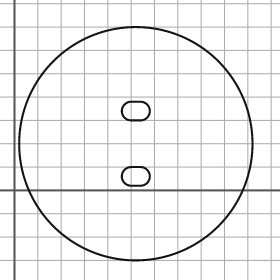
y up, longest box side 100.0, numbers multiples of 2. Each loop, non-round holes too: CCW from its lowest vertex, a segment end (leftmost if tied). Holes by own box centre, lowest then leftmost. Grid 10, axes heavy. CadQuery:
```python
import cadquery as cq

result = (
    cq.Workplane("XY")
    .moveTo(52.0, 20.0)
    .circle(50.0)
    .moveTo(50.0, 2.0)
    .lineTo(54.0, 2.0)
    .threePointArc((58.0, 6.0), (54.0, 10.0))
    .lineTo(50.0, 10.0)
    .threePointArc((46.0, 6.0), (50.0, 2.0))
    .close()
    .moveTo(50.0, 30.0)
    .lineTo(54.0, 30.0)
    .threePointArc((58.0, 34.0), (54.0, 38.0))
    .lineTo(50.0, 38.0)
    .threePointArc((46.0, 34.0), (50.0, 30.0))
    .close()
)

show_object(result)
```